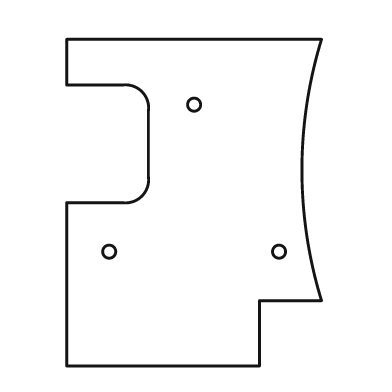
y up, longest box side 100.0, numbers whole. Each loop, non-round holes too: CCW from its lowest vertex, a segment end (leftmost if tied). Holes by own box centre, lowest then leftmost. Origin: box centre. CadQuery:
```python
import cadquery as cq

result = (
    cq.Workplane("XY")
    .moveTo(-39.0, -50.0)
    .lineTo(20.0, -50.0)
    .lineTo(20.0, -30.0)
    .lineTo(39.0, -30.0)
    .threePointArc((33.0, 10.0), (39.0, 50.0))
    .lineTo(-39.0, 50.0)
    .lineTo(-39.0, 36.0)
    .lineTo(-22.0, 36.0)
    .threePointArc((-16.0, 34.0), (-14.0, 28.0))
    .lineTo(-14.0, 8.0)
    .threePointArc((-16.0, 2.0), (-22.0, 0.0))
    .lineTo(-39.0, 0.0)
    .close()
    .moveTo(-26.0, -15.0)
    .circle(2.0)
    .moveTo(26.0, -15.0)
    .circle(2.0)
    .moveTo(0.0, 30.0)
    .circle(2.0)
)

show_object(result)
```